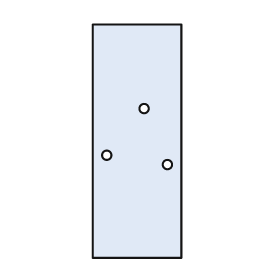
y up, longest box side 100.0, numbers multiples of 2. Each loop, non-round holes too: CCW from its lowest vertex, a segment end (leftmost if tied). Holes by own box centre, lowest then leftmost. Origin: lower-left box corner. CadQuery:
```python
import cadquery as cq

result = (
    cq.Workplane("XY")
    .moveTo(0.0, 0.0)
    .lineTo(38.0, 0.0)
    .lineTo(38.0, 100.0)
    .lineTo(0.0, 100.0)
    .close()
    .moveTo(32.0, 40.0)
    .circle(2.0)
    .moveTo(6.0, 44.0)
    .circle(2.0)
    .moveTo(22.0, 64.0)
    .circle(2.0)
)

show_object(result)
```